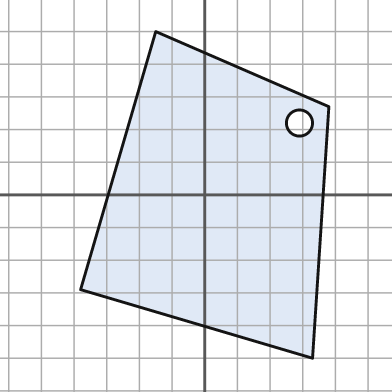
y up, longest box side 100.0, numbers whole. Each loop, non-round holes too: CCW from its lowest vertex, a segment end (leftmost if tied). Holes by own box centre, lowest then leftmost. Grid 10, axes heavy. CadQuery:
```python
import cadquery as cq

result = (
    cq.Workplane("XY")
    .moveTo(33.0, -50.0)
    .lineTo(38.0, 27.0)
    .lineTo(-15.0, 50.0)
    .lineTo(-38.0, -29.0)
    .close()
    .moveTo(29.0, 22.0)
    .circle(4.0)
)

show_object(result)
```